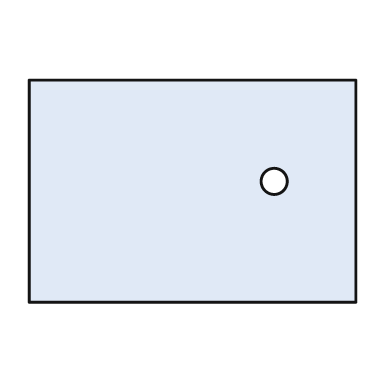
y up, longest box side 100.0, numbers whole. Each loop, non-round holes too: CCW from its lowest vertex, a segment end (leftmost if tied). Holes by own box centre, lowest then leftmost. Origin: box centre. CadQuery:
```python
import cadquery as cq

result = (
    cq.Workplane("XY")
    .moveTo(-50.0, -34.0)
    .lineTo(50.0, -34.0)
    .lineTo(50.0, 34.0)
    .lineTo(-50.0, 34.0)
    .close()
    .moveTo(25.0, 3.0)
    .circle(4.0)
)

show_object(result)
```